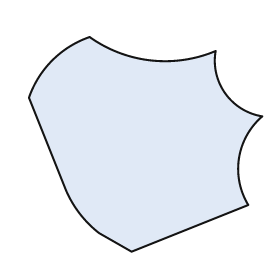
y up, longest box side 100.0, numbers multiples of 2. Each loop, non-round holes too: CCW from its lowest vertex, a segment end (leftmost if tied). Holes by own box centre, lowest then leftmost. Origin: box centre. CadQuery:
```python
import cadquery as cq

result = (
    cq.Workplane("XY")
    .moveTo(-6.0, -46.0)
    .lineTo(44.0, -26.0)
    .threePointArc((40.0, -6.0), (50.0, 12.0))
    .threePointArc((34.0, 22.0), (30.0, 40.0))
    .threePointArc((2.0, 36.0), (-24.0, 46.0))
    .threePointArc((-40.0, 36.0), (-50.0, 20.0))
    .lineTo(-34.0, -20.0)
    .threePointArc((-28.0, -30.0), (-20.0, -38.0))
    .close()
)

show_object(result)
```